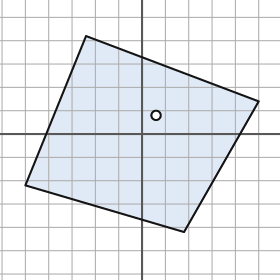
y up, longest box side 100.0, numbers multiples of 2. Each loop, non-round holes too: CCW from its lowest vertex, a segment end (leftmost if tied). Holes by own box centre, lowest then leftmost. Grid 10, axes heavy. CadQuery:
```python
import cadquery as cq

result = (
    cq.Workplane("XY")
    .moveTo(18.0, -42.0)
    .lineTo(50.0, 14.0)
    .lineTo(-24.0, 42.0)
    .lineTo(-50.0, -22.0)
    .close()
    .moveTo(6.0, 8.0)
    .circle(2.0)
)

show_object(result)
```